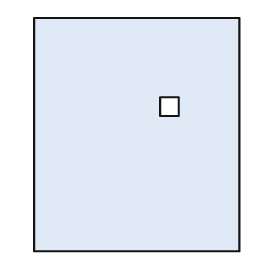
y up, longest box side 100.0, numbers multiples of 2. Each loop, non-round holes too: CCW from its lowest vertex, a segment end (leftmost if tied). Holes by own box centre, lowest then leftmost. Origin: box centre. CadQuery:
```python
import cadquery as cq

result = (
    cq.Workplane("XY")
    .moveTo(-44.0, -50.0)
    .lineTo(44.0, -50.0)
    .lineTo(44.0, 50.0)
    .lineTo(-44.0, 50.0)
    .close()
    .moveTo(10.0, 8.0)
    .lineTo(18.0, 8.0)
    .lineTo(18.0, 16.0)
    .lineTo(10.0, 16.0)
    .close()
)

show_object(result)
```